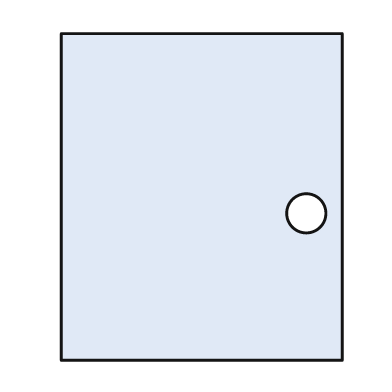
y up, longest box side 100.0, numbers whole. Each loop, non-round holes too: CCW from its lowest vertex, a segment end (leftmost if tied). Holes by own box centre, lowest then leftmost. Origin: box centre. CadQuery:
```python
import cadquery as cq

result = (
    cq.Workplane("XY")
    .moveTo(-43.0, -50.0)
    .lineTo(43.0, -50.0)
    .lineTo(43.0, 50.0)
    .lineTo(-43.0, 50.0)
    .close()
    .moveTo(32.0, -5.0)
    .circle(6.0)
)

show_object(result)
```